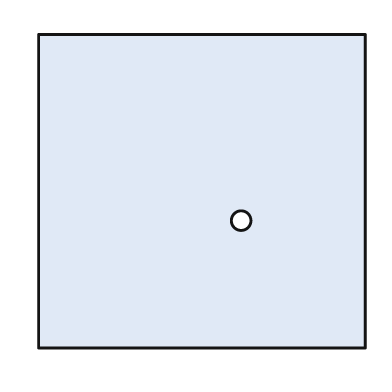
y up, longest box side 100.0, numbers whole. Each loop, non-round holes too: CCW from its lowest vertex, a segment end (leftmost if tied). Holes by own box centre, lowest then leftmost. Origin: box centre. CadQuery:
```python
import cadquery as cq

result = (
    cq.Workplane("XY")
    .moveTo(-50.0, -48.0)
    .lineTo(50.0, -48.0)
    .lineTo(50.0, 48.0)
    .lineTo(-50.0, 48.0)
    .close()
    .moveTo(12.0, -9.0)
    .circle(3.0)
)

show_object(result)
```